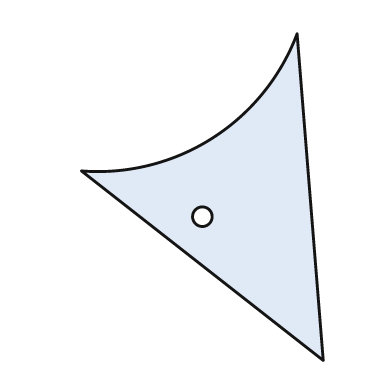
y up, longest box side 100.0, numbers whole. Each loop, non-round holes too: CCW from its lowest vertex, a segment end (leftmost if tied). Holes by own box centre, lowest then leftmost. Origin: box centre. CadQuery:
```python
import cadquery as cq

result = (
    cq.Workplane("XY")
    .moveTo(37.0, -50.0)
    .lineTo(29.0, 50.0)
    .threePointArc((3.0, 18.0), (-37.0, 8.0))
    .close()
    .moveTo(0.0, -6.0)
    .circle(3.0)
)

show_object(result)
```